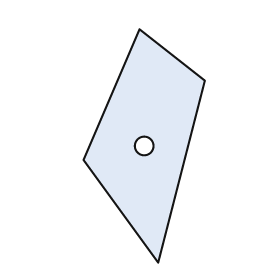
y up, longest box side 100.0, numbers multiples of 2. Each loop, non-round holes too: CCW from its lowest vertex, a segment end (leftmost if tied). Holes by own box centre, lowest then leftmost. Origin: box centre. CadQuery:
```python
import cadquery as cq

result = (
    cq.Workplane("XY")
    .moveTo(6.0, -50.0)
    .lineTo(26.0, 28.0)
    .lineTo(-2.0, 50.0)
    .lineTo(-26.0, -6.0)
    .close()
    .moveTo(0.0, 0.0)
    .circle(4.0)
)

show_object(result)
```